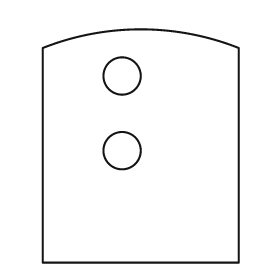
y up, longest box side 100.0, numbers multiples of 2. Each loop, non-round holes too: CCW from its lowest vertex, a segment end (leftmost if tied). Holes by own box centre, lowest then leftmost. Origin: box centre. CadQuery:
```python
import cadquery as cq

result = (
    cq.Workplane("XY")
    .moveTo(-42.0, -50.0)
    .lineTo(42.0, -50.0)
    .lineTo(42.0, 42.0)
    .threePointArc((0.0, 50.0), (-42.0, 42.0))
    .close()
    .moveTo(-8.0, -2.0)
    .circle(8.0)
    .moveTo(-8.0, 30.0)
    .circle(8.0)
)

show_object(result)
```